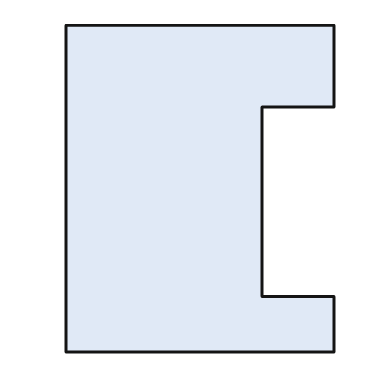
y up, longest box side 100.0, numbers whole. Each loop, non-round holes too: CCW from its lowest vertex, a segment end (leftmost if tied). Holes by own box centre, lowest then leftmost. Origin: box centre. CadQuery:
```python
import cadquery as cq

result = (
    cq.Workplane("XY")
    .moveTo(-41.0, -50.0)
    .lineTo(41.0, -50.0)
    .lineTo(41.0, -33.0)
    .lineTo(19.0, -33.0)
    .lineTo(19.0, 25.0)
    .lineTo(41.0, 25.0)
    .lineTo(41.0, 50.0)
    .lineTo(-41.0, 50.0)
    .close()
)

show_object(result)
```